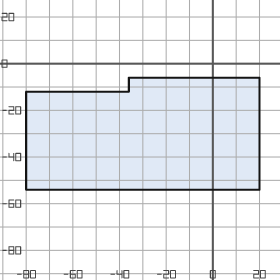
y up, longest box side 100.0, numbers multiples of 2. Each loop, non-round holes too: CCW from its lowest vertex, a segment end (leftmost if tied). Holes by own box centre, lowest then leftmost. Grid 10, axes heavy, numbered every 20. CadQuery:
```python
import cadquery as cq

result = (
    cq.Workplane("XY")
    .moveTo(-80.0, -54.0)
    .lineTo(20.0, -54.0)
    .lineTo(20.0, -6.0)
    .lineTo(-36.0, -6.0)
    .lineTo(-36.0, -12.0)
    .lineTo(-80.0, -12.0)
    .close()
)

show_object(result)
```